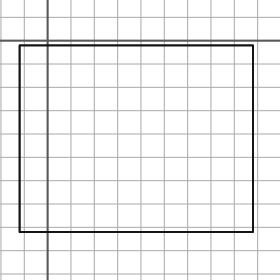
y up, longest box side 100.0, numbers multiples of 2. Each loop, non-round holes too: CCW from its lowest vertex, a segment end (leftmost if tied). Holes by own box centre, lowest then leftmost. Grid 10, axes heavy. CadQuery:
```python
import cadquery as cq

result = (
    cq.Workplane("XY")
    .moveTo(-12.0, -82.0)
    .lineTo(88.0, -82.0)
    .lineTo(88.0, -2.0)
    .lineTo(-12.0, -2.0)
    .close()
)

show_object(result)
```